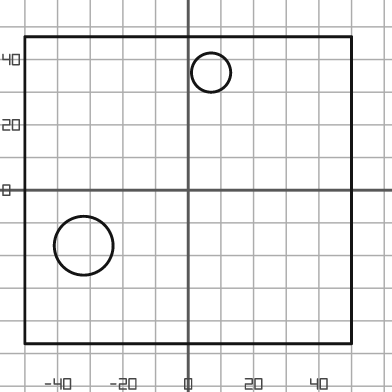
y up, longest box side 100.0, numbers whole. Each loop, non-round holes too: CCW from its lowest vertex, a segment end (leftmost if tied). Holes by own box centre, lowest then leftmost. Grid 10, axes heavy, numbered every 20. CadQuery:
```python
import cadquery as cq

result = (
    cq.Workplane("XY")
    .moveTo(-50.0, -47.0)
    .lineTo(50.0, -47.0)
    .lineTo(50.0, 47.0)
    .lineTo(-50.0, 47.0)
    .close()
    .moveTo(-32.0, -17.0)
    .circle(9.0)
    .moveTo(7.0, 36.0)
    .circle(6.0)
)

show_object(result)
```